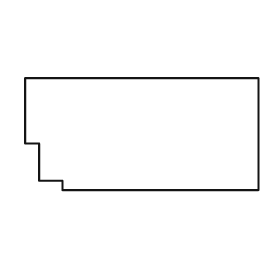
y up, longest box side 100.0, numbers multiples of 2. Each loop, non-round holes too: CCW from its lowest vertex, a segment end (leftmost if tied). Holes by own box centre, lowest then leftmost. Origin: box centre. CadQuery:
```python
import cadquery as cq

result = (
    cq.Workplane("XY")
    .moveTo(-34.0, -24.0)
    .lineTo(50.0, -24.0)
    .lineTo(50.0, 24.0)
    .lineTo(-50.0, 24.0)
    .lineTo(-50.0, -4.0)
    .lineTo(-44.0, -4.0)
    .lineTo(-44.0, -20.0)
    .lineTo(-34.0, -20.0)
    .close()
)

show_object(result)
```